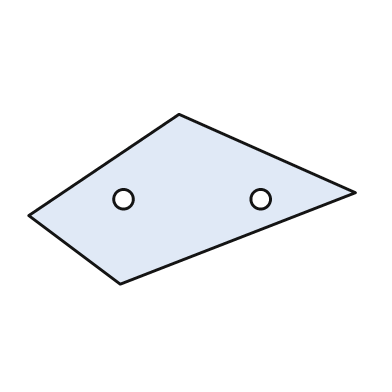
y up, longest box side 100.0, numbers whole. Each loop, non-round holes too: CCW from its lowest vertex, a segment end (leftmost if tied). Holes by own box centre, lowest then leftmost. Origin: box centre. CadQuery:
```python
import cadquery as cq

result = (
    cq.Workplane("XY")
    .moveTo(-22.0, -26.0)
    .lineTo(50.0, 2.0)
    .lineTo(-4.0, 26.0)
    .lineTo(-50.0, -5.0)
    .close()
    .moveTo(-21.0, 0.0)
    .circle(3.0)
    .moveTo(21.0, 0.0)
    .circle(3.0)
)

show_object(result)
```